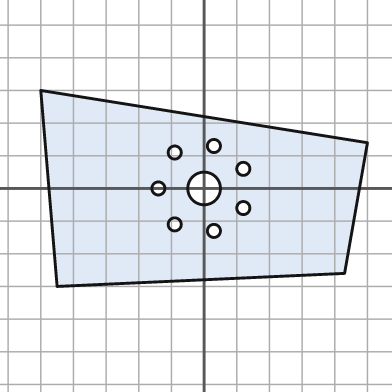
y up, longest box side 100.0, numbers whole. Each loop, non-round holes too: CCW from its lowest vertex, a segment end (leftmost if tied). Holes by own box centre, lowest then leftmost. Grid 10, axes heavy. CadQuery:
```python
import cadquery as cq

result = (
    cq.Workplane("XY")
    .moveTo(-45.0, -30.0)
    .lineTo(43.0, -26.0)
    .lineTo(50.0, 14.0)
    .lineTo(-50.0, 30.0)
    .close()
    .moveTo(3.0, -13.0)
    .circle(2.0)
    .moveTo(-9.0, -11.0)
    .circle(2.0)
    .moveTo(12.0, -6.0)
    .circle(2.0)
    .moveTo(-14.0, 0.0)
    .circle(2.0)
    .moveTo(0.0, 0.0)
    .circle(5.0)
    .moveTo(12.0, 6.0)
    .circle(2.0)
    .moveTo(-9.0, 11.0)
    .circle(2.0)
    .moveTo(3.0, 13.0)
    .circle(2.0)
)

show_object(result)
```